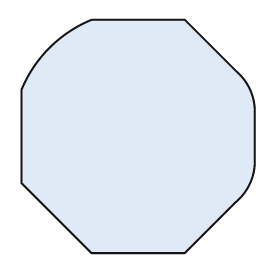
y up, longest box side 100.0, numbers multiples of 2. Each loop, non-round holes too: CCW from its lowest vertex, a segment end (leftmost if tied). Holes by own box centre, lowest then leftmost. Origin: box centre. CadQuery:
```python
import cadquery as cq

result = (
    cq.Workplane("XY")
    .moveTo(-20.0, -50.0)
    .lineTo(20.0, -50.0)
    .lineTo(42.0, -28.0)
    .threePointArc((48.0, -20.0), (50.0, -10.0))
    .lineTo(50.0, 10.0)
    .threePointArc((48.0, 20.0), (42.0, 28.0))
    .lineTo(20.0, 50.0)
    .lineTo(-20.0, 50.0)
    .threePointArc((-38.0, 38.0), (-50.0, 20.0))
    .lineTo(-50.0, -20.0)
    .close()
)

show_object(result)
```